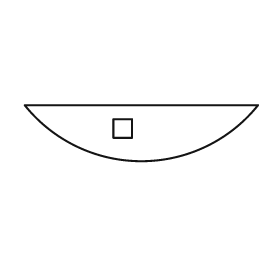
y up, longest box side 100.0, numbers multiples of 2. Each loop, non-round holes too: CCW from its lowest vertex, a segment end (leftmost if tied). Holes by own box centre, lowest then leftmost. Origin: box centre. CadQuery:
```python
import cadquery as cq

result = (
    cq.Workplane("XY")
    .moveTo(-50.0, 12.0)
    .threePointArc((0.0, -12.0), (50.0, 12.0))
    .close()
    .moveTo(-12.0, -2.0)
    .lineTo(-4.0, -2.0)
    .lineTo(-4.0, 6.0)
    .lineTo(-12.0, 6.0)
    .close()
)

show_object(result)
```